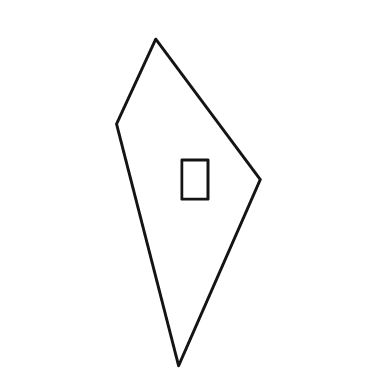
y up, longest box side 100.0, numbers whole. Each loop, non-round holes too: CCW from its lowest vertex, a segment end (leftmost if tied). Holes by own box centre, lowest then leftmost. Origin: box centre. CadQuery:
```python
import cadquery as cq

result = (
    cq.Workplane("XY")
    .moveTo(-3.0, -50.0)
    .lineTo(22.0, 7.0)
    .lineTo(-10.0, 50.0)
    .lineTo(-22.0, 24.0)
    .close()
    .moveTo(-2.0, 1.0)
    .lineTo(6.0, 1.0)
    .lineTo(6.0, 13.0)
    .lineTo(-2.0, 13.0)
    .close()
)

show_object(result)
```